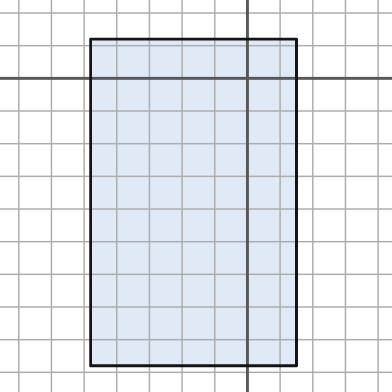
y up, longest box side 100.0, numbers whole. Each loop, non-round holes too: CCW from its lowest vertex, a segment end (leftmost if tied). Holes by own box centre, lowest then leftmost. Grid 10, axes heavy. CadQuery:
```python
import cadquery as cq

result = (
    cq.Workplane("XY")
    .moveTo(-48.0, -88.0)
    .lineTo(15.0, -88.0)
    .lineTo(15.0, 12.0)
    .lineTo(-48.0, 12.0)
    .close()
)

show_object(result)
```